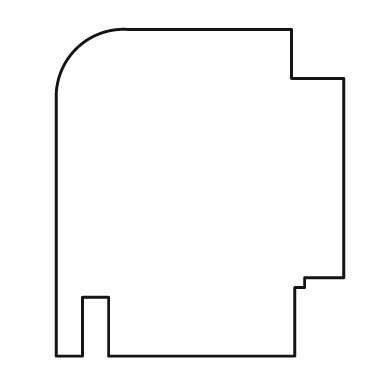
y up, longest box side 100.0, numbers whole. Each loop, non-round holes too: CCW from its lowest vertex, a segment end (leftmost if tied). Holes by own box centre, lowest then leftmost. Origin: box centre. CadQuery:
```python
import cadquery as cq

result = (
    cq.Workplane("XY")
    .moveTo(-44.0, -50.0)
    .lineTo(-36.0, -50.0)
    .lineTo(-36.0, -32.0)
    .lineTo(-28.0, -32.0)
    .lineTo(-28.0, -50.0)
    .lineTo(29.0, -50.0)
    .lineTo(29.0, -29.0)
    .lineTo(32.0, -29.0)
    .lineTo(32.0, -26.0)
    .lineTo(44.0, -26.0)
    .lineTo(44.0, 35.0)
    .lineTo(28.0, 35.0)
    .lineTo(28.0, 50.0)
    .lineTo(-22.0, 50.0)
    .threePointArc((-38.0, 44.0), (-44.0, 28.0))
    .close()
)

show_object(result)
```